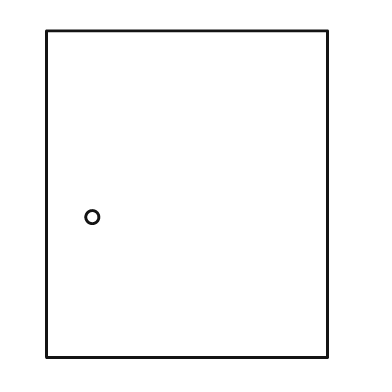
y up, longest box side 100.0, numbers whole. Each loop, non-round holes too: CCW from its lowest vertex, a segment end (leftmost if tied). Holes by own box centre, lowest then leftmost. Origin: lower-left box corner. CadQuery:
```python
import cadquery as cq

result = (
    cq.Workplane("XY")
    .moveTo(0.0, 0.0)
    .lineTo(86.0, 0.0)
    .lineTo(86.0, 100.0)
    .lineTo(0.0, 100.0)
    .close()
    .moveTo(14.0, 43.0)
    .circle(2.0)
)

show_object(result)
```